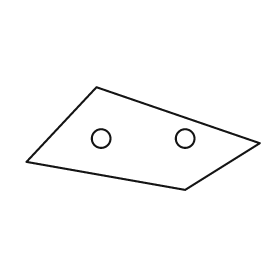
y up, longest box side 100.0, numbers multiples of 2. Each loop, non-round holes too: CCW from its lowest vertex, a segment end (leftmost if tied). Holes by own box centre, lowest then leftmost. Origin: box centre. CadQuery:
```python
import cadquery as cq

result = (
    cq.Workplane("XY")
    .moveTo(18.0, -22.0)
    .lineTo(50.0, -2.0)
    .lineTo(-20.0, 22.0)
    .lineTo(-50.0, -10.0)
    .close()
    .moveTo(-18.0, 0.0)
    .circle(4.0)
    .moveTo(18.0, 0.0)
    .circle(4.0)
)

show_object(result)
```